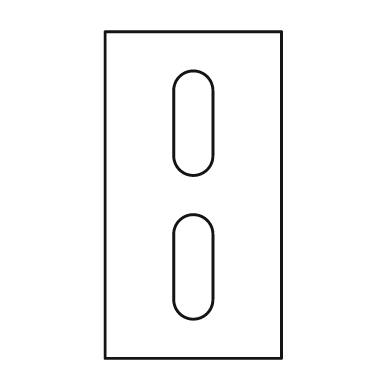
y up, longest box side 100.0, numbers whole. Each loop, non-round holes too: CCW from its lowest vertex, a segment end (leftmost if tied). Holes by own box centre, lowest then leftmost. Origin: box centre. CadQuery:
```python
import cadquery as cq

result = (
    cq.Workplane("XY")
    .moveTo(-27.0, -50.0)
    .lineTo(27.0, -50.0)
    .lineTo(27.0, 50.0)
    .lineTo(-27.0, 50.0)
    .close()
    .moveTo(-6.0, -32.0)
    .threePointArc((0.0, -38.0), (6.0, -32.0))
    .lineTo(6.0, -12.0)
    .threePointArc((0.0, -6.0), (-6.0, -12.0))
    .close()
    .moveTo(-6.0, 12.0)
    .threePointArc((0.0, 6.0), (6.0, 12.0))
    .lineTo(6.0, 32.0)
    .threePointArc((0.0, 38.0), (-6.0, 32.0))
    .close()
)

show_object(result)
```